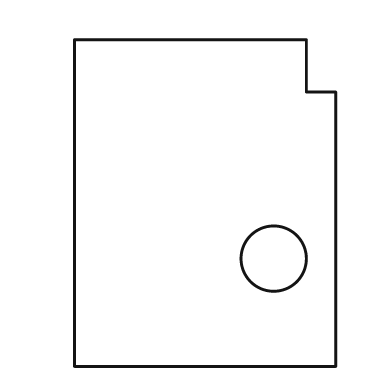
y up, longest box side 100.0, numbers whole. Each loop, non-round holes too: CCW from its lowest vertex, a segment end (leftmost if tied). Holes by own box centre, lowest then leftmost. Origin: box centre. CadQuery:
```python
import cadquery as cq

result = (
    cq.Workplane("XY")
    .moveTo(-40.0, -50.0)
    .lineTo(40.0, -50.0)
    .lineTo(40.0, 34.0)
    .lineTo(31.0, 34.0)
    .lineTo(31.0, 50.0)
    .lineTo(-40.0, 50.0)
    .close()
    .moveTo(21.0, -17.0)
    .circle(10.0)
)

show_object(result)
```